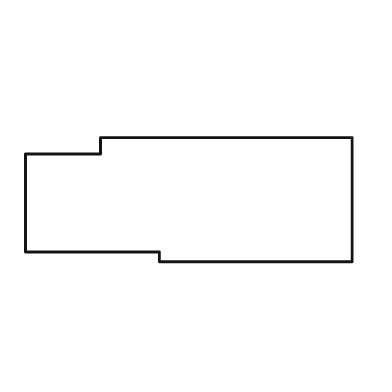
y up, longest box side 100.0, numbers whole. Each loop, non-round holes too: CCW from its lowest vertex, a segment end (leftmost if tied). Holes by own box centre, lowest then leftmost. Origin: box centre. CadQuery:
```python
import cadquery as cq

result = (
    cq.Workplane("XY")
    .moveTo(-9.0, -19.0)
    .lineTo(50.0, -19.0)
    .lineTo(50.0, 19.0)
    .lineTo(-27.0, 19.0)
    .lineTo(-27.0, 14.0)
    .lineTo(-50.0, 14.0)
    .lineTo(-50.0, -16.0)
    .lineTo(-9.0, -16.0)
    .close()
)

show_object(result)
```